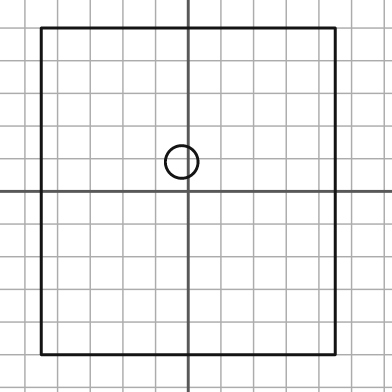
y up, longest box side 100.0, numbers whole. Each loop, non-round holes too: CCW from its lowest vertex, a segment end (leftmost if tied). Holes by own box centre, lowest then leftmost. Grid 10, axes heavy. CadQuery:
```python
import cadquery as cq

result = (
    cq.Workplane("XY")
    .moveTo(-45.0, -50.0)
    .lineTo(45.0, -50.0)
    .lineTo(45.0, 50.0)
    .lineTo(-45.0, 50.0)
    .close()
    .moveTo(-2.0, 9.0)
    .circle(5.0)
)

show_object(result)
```